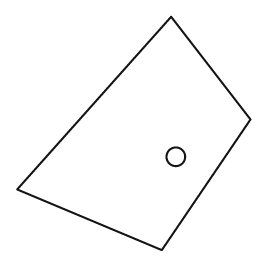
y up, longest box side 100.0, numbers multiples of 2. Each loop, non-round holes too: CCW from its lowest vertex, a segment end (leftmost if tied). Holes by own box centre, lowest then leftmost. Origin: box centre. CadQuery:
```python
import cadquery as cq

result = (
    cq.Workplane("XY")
    .moveTo(12.0, -50.0)
    .lineTo(50.0, 6.0)
    .lineTo(16.0, 50.0)
    .lineTo(-50.0, -24.0)
    .close()
    .moveTo(18.0, -10.0)
    .circle(4.0)
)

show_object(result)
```